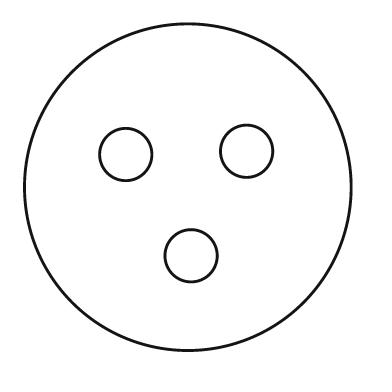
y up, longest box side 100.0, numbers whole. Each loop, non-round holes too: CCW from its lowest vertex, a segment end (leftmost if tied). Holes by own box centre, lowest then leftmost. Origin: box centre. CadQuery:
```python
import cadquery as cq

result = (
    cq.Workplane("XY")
    .moveTo(0.0, 0.0)
    .circle(50.0)
    .moveTo(1.0, -21.0)
    .circle(8.0)
    .moveTo(-19.0, 10.0)
    .circle(8.0)
    .moveTo(18.0, 11.0)
    .circle(8.0)
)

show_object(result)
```